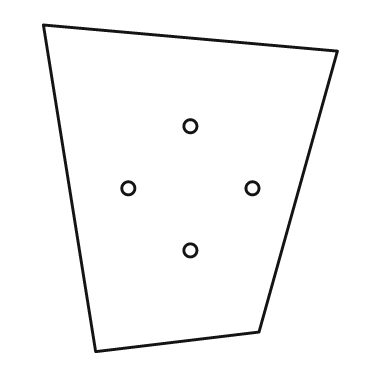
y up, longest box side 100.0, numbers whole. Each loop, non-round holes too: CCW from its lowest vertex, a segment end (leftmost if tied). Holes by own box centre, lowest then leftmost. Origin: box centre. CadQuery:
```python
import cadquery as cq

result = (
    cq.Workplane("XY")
    .moveTo(-29.0, -50.0)
    .lineTo(21.0, -44.0)
    .lineTo(45.0, 42.0)
    .lineTo(-45.0, 50.0)
    .close()
    .moveTo(0.0, -19.0)
    .circle(2.0)
    .moveTo(-19.0, 0.0)
    .circle(2.0)
    .moveTo(19.0, 0.0)
    .circle(2.0)
    .moveTo(0.0, 19.0)
    .circle(2.0)
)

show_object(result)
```